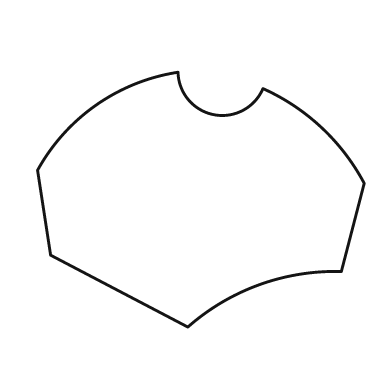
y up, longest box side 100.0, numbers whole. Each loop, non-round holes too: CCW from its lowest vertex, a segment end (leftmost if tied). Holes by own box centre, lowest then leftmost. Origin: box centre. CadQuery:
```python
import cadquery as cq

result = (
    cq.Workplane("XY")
    .moveTo(-4.0, -39.0)
    .threePointArc((18.0, -26.0), (43.0, -22.0))
    .lineTo(50.0, 5.0)
    .threePointArc((37.0, 22.0), (19.0, 34.0))
    .threePointArc((4.0, 26.0), (-7.0, 39.0))
    .threePointArc((-32.0, 29.0), (-50.0, 9.0))
    .lineTo(-46.0, -17.0)
    .close()
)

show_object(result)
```